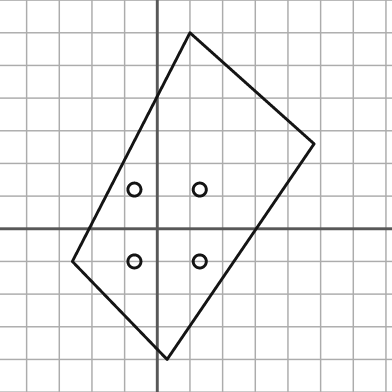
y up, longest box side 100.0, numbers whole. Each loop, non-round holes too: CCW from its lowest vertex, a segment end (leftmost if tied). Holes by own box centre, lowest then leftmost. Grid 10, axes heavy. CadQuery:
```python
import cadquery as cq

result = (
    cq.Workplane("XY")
    .moveTo(3.0, -40.0)
    .lineTo(48.0, 26.0)
    .lineTo(10.0, 60.0)
    .lineTo(-26.0, -10.0)
    .close()
    .moveTo(-7.0, -10.0)
    .circle(2.0)
    .moveTo(13.0, -10.0)
    .circle(2.0)
    .moveTo(-7.0, 12.0)
    .circle(2.0)
    .moveTo(13.0, 12.0)
    .circle(2.0)
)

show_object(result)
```